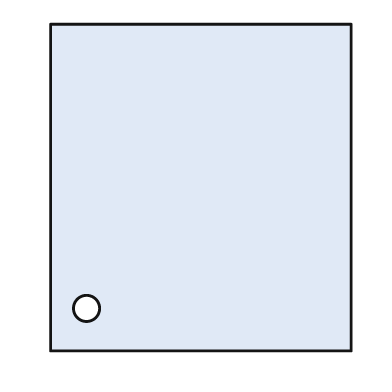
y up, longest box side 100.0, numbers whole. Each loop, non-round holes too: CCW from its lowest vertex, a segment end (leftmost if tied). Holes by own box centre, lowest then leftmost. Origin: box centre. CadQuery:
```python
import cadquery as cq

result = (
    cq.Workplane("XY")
    .moveTo(-46.0, -50.0)
    .lineTo(46.0, -50.0)
    .lineTo(46.0, 50.0)
    .lineTo(-46.0, 50.0)
    .close()
    .moveTo(-35.0, -37.0)
    .circle(4.0)
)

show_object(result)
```